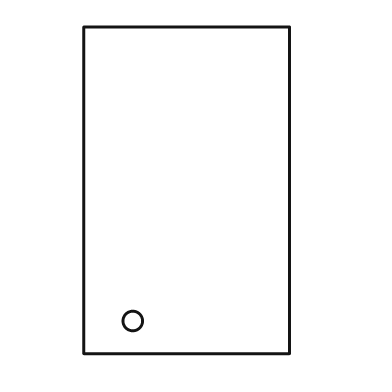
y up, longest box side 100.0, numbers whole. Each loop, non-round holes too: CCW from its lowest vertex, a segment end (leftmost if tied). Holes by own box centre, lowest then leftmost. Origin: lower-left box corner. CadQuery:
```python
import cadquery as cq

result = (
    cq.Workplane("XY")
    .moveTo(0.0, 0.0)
    .lineTo(63.0, 0.0)
    .lineTo(63.0, 100.0)
    .lineTo(0.0, 100.0)
    .close()
    .moveTo(15.0, 10.0)
    .circle(3.0)
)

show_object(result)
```